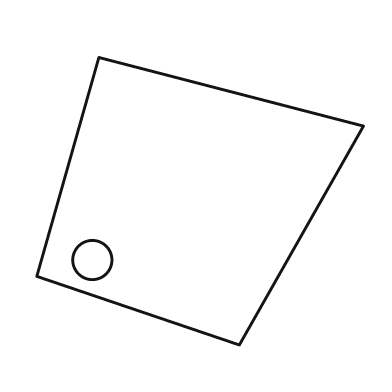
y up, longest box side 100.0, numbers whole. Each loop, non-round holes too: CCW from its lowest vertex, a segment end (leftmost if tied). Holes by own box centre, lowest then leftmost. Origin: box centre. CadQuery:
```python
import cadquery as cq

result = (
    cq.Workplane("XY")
    .moveTo(12.0, -44.0)
    .lineTo(50.0, 23.0)
    .lineTo(-31.0, 44.0)
    .lineTo(-50.0, -23.0)
    .close()
    .moveTo(-33.0, -18.0)
    .circle(6.0)
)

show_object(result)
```